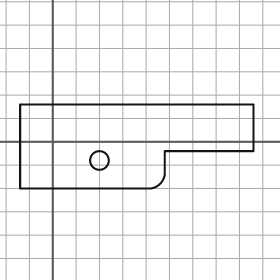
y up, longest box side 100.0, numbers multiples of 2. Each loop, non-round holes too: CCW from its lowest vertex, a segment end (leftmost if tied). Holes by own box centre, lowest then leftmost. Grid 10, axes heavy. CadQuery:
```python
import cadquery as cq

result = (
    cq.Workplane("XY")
    .moveTo(-14.0, -20.0)
    .lineTo(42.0, -20.0)
    .threePointArc((46.0, -18.0), (48.0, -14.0))
    .lineTo(48.0, -4.0)
    .lineTo(86.0, -4.0)
    .lineTo(86.0, 16.0)
    .lineTo(-14.0, 16.0)
    .close()
    .moveTo(20.0, -8.0)
    .circle(4.0)
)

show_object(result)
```